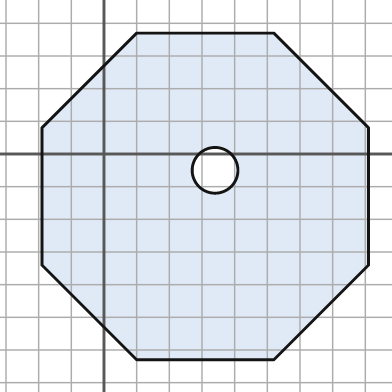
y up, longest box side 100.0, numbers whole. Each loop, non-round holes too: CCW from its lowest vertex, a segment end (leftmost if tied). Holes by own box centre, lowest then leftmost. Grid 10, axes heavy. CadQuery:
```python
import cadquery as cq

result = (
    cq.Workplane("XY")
    .moveTo(10.0, -63.0)
    .lineTo(52.0, -63.0)
    .lineTo(81.0, -34.0)
    .lineTo(81.0, 8.0)
    .lineTo(52.0, 37.0)
    .lineTo(10.0, 37.0)
    .lineTo(-19.0, 8.0)
    .lineTo(-19.0, -34.0)
    .close()
    .moveTo(34.0, -5.0)
    .circle(7.0)
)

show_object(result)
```